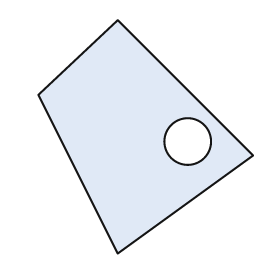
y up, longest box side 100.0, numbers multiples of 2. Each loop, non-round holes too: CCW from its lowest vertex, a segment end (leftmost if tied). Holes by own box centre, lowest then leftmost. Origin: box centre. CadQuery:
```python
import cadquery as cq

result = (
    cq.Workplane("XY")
    .moveTo(-12.0, -50.0)
    .lineTo(46.0, -8.0)
    .lineTo(-12.0, 50.0)
    .lineTo(-46.0, 18.0)
    .close()
    .moveTo(18.0, -2.0)
    .circle(10.0)
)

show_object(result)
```